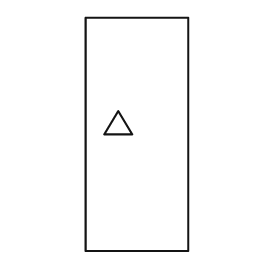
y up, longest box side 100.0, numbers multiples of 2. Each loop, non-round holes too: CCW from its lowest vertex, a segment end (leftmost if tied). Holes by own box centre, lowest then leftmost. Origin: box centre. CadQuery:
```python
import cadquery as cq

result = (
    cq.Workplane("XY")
    .moveTo(-22.0, -50.0)
    .lineTo(22.0, -50.0)
    .lineTo(22.0, 50.0)
    .lineTo(-22.0, 50.0)
    .close()
    .moveTo(-14.0, 0.0)
    .lineTo(-2.0, 0.0)
    .lineTo(-8.0, 10.0)
    .close()
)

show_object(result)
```